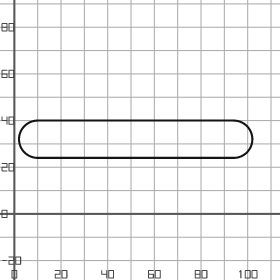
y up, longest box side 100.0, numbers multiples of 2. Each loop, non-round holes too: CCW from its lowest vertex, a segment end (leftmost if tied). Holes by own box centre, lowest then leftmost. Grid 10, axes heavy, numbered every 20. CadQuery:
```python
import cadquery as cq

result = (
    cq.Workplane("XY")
    .moveTo(10.0, 24.0)
    .lineTo(94.0, 24.0)
    .threePointArc((102.0, 32.0), (94.0, 40.0))
    .lineTo(10.0, 40.0)
    .threePointArc((2.0, 32.0), (10.0, 24.0))
    .close()
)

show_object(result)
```